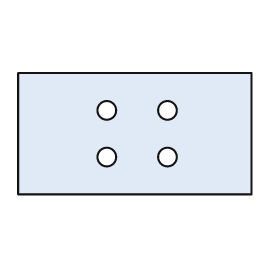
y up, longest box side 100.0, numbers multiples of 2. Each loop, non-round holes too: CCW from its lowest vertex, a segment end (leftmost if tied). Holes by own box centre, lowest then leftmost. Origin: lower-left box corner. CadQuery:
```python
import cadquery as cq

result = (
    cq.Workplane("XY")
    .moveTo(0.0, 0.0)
    .lineTo(100.0, 0.0)
    .lineTo(100.0, 52.0)
    .lineTo(0.0, 52.0)
    .close()
    .moveTo(38.0, 16.0)
    .circle(4.0)
    .moveTo(64.0, 16.0)
    .circle(4.0)
    .moveTo(38.0, 36.0)
    .circle(4.0)
    .moveTo(64.0, 36.0)
    .circle(4.0)
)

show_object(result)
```